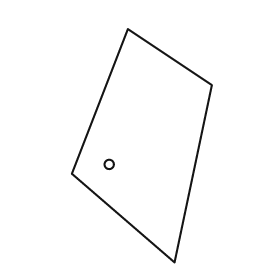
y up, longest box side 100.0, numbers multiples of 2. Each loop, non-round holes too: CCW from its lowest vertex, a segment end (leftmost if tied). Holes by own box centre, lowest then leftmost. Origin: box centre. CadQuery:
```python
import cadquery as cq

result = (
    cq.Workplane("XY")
    .moveTo(14.0, -50.0)
    .lineTo(30.0, 26.0)
    .lineTo(-6.0, 50.0)
    .lineTo(-30.0, -12.0)
    .close()
    .moveTo(-14.0, -8.0)
    .circle(2.0)
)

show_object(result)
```